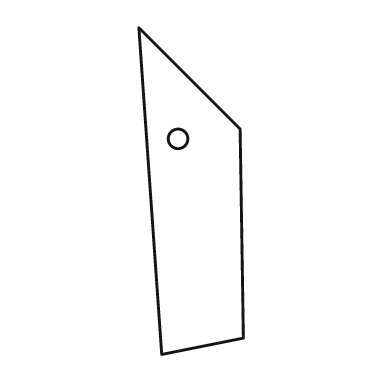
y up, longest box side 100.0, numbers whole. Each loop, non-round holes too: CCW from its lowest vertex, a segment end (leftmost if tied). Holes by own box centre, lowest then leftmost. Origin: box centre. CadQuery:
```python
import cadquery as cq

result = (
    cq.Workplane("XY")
    .moveTo(-9.0, -50.0)
    .lineTo(16.0, -45.0)
    .lineTo(15.0, 19.0)
    .lineTo(-16.0, 50.0)
    .close()
    .moveTo(-4.0, 16.0)
    .circle(3.0)
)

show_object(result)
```